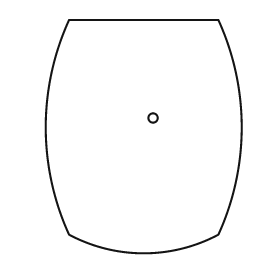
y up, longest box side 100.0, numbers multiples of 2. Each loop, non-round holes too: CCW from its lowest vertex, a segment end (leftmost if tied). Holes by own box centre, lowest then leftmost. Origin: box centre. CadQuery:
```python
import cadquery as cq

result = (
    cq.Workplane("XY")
    .moveTo(-32.0, -42.0)
    .threePointArc((0.0, -50.0), (32.0, -42.0))
    .threePointArc((42.0, 4.0), (32.0, 50.0))
    .lineTo(-32.0, 50.0)
    .threePointArc((-42.0, 4.0), (-32.0, -42.0))
    .close()
    .moveTo(4.0, 8.0)
    .circle(2.0)
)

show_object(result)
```